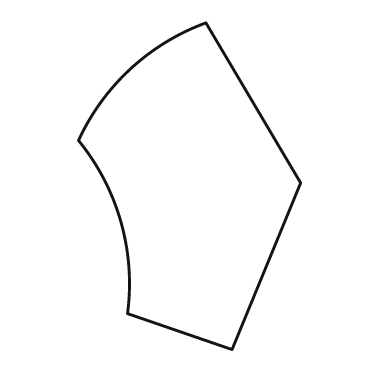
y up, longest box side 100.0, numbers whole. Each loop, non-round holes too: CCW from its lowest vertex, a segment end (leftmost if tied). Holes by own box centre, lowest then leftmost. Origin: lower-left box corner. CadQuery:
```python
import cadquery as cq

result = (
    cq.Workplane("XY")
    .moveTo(47.0, 0.0)
    .lineTo(68.0, 51.0)
    .lineTo(39.0, 100.0)
    .threePointArc((16.0, 86.0), (0.0, 64.0))
    .threePointArc((13.0, 39.0), (15.0, 11.0))
    .close()
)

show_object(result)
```